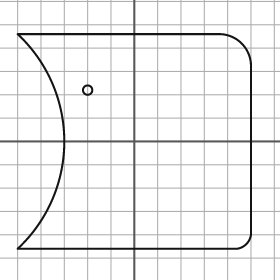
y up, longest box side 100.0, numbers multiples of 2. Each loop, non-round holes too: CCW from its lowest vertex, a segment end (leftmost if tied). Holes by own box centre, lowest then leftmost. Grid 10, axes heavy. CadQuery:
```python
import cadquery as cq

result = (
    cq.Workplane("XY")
    .moveTo(-50.0, -46.0)
    .lineTo(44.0, -46.0)
    .threePointArc((48.0, -44.0), (50.0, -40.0))
    .lineTo(50.0, 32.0)
    .threePointArc((46.0, 42.0), (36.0, 46.0))
    .lineTo(-50.0, 46.0)
    .threePointArc((-30.0, 0.0), (-50.0, -46.0))
    .close()
    .moveTo(-20.0, 22.0)
    .circle(2.0)
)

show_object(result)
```